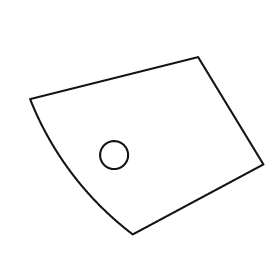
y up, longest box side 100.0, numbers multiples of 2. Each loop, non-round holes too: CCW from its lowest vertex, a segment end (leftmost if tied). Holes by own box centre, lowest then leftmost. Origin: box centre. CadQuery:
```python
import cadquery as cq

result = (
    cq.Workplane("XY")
    .moveTo(-6.0, -38.0)
    .lineTo(50.0, -8.0)
    .lineTo(22.0, 38.0)
    .lineTo(-50.0, 20.0)
    .threePointArc((-32.0, -12.0), (-6.0, -38.0))
    .close()
    .moveTo(-14.0, -4.0)
    .circle(6.0)
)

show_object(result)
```